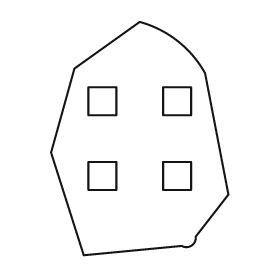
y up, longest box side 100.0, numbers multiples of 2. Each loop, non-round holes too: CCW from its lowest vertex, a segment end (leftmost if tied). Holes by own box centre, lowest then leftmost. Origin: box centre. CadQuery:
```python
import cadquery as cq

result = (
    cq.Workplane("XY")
    .moveTo(-24.0, -50.0)
    .lineTo(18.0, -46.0)
    .threePointArc((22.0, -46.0), (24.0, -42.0))
    .lineTo(38.0, -24.0)
    .lineTo(28.0, 28.0)
    .threePointArc((16.0, 42.0), (0.0, 50.0))
    .lineTo(-28.0, 30.0)
    .lineTo(-38.0, -6.0)
    .close()
    .moveTo(-22.0, -22.0)
    .lineTo(-10.0, -22.0)
    .lineTo(-10.0, -10.0)
    .lineTo(-22.0, -10.0)
    .close()
    .moveTo(10.0, -22.0)
    .lineTo(22.0, -22.0)
    .lineTo(22.0, -10.0)
    .lineTo(10.0, -10.0)
    .close()
    .moveTo(-22.0, 10.0)
    .lineTo(-10.0, 10.0)
    .lineTo(-10.0, 22.0)
    .lineTo(-22.0, 22.0)
    .close()
    .moveTo(10.0, 10.0)
    .lineTo(22.0, 10.0)
    .lineTo(22.0, 22.0)
    .lineTo(10.0, 22.0)
    .close()
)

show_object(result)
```